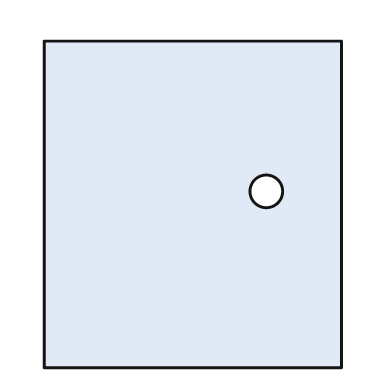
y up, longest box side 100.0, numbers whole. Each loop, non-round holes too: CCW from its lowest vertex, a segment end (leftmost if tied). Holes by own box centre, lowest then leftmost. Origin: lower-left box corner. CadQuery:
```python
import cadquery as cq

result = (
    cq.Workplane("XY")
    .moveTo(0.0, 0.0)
    .lineTo(91.0, 0.0)
    .lineTo(91.0, 100.0)
    .lineTo(0.0, 100.0)
    .close()
    .moveTo(68.0, 54.0)
    .circle(5.0)
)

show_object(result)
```